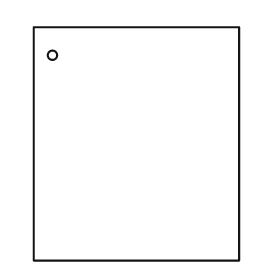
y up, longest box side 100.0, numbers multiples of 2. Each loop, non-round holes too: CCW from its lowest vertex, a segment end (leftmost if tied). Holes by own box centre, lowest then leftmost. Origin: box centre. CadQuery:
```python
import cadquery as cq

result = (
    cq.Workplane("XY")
    .moveTo(-44.0, -50.0)
    .lineTo(44.0, -50.0)
    .lineTo(44.0, 50.0)
    .lineTo(-44.0, 50.0)
    .close()
    .moveTo(-36.0, 38.0)
    .circle(2.0)
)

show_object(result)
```